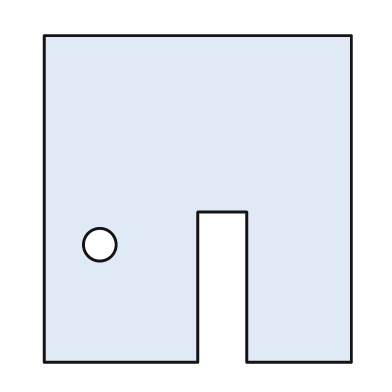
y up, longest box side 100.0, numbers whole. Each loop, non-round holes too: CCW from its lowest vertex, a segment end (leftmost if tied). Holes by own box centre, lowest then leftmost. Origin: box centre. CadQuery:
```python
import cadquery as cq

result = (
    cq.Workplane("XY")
    .moveTo(-47.0, -50.0)
    .lineTo(0.0, -50.0)
    .lineTo(0.0, -4.0)
    .lineTo(15.0, -4.0)
    .lineTo(15.0, -50.0)
    .lineTo(47.0, -50.0)
    .lineTo(47.0, 50.0)
    .lineTo(-47.0, 50.0)
    .close()
    .moveTo(-30.0, -14.0)
    .circle(5.0)
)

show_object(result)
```